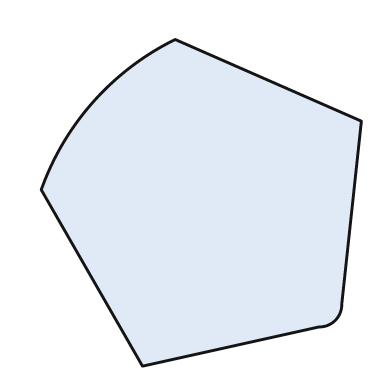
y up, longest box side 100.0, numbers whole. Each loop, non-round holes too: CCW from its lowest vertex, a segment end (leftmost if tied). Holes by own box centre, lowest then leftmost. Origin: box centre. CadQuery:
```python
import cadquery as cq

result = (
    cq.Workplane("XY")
    .moveTo(-18.0, -50.0)
    .lineTo(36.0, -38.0)
    .threePointArc((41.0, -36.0), (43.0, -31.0))
    .lineTo(49.0, 25.0)
    .lineTo(-8.0, 50.0)
    .threePointArc((-33.0, 31.0), (-49.0, 4.0))
    .close()
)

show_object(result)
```